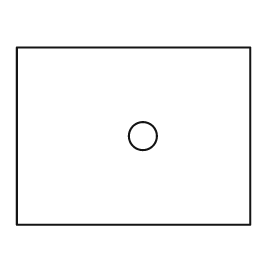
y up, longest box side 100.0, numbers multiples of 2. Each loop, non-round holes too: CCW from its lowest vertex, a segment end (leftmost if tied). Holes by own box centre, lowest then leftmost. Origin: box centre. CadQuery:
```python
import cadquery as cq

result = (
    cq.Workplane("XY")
    .moveTo(-50.0, -38.0)
    .lineTo(50.0, -38.0)
    .lineTo(50.0, 38.0)
    .lineTo(-50.0, 38.0)
    .close()
    .moveTo(4.0, 0.0)
    .circle(6.0)
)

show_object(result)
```